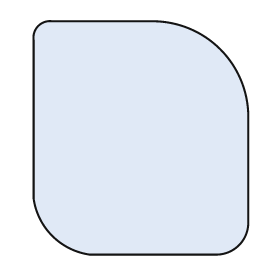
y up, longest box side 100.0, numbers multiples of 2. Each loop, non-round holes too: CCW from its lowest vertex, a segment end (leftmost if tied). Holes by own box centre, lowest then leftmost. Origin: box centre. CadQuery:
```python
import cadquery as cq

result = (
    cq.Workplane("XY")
    .moveTo(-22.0, -50.0)
    .lineTo(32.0, -50.0)
    .threePointArc((42.0, -46.0), (46.0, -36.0))
    .lineTo(46.0, 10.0)
    .threePointArc((34.0, 38.0), (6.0, 50.0))
    .lineTo(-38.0, 50.0)
    .threePointArc((-44.0, 48.0), (-46.0, 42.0))
    .lineTo(-46.0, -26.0)
    .threePointArc((-38.0, -42.0), (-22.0, -50.0))
    .close()
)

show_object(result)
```